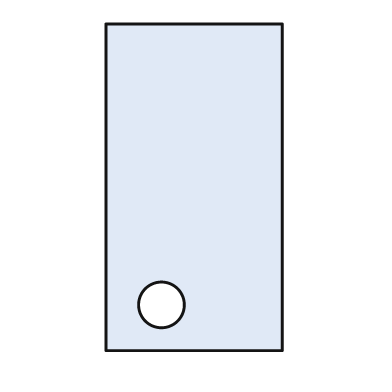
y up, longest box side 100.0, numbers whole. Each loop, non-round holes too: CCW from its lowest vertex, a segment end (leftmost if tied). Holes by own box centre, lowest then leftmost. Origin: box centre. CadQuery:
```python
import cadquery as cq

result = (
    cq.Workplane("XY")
    .moveTo(-27.0, -50.0)
    .lineTo(27.0, -50.0)
    .lineTo(27.0, 50.0)
    .lineTo(-27.0, 50.0)
    .close()
    .moveTo(-10.0, -36.0)
    .circle(7.0)
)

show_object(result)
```